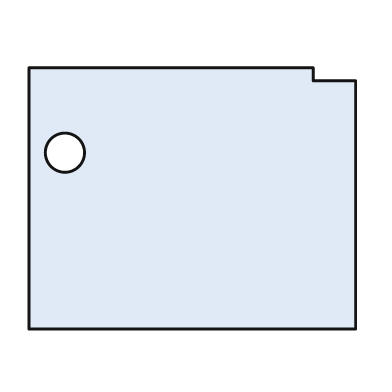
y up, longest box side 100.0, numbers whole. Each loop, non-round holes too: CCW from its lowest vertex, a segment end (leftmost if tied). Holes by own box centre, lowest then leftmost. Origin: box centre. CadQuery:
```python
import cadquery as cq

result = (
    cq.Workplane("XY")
    .moveTo(-50.0, -40.0)
    .lineTo(50.0, -40.0)
    .lineTo(50.0, 36.0)
    .lineTo(37.0, 36.0)
    .lineTo(37.0, 40.0)
    .lineTo(-50.0, 40.0)
    .close()
    .moveTo(-39.0, 14.0)
    .circle(6.0)
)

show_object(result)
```